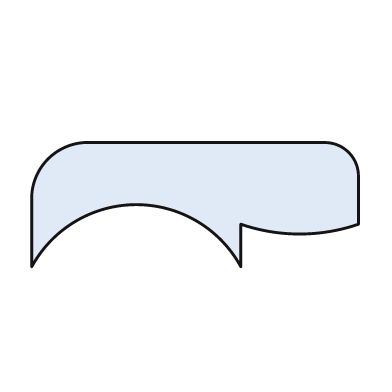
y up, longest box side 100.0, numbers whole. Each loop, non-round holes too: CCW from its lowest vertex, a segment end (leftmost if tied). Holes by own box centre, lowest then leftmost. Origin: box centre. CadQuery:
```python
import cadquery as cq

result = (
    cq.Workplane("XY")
    .moveTo(-50.0, -19.0)
    .threePointArc((-18.0, 0.0), (14.0, -19.0))
    .lineTo(14.0, -6.0)
    .threePointArc((32.0, -9.0), (50.0, -6.0))
    .lineTo(50.0, 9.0)
    .threePointArc((47.0, 16.0), (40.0, 19.0))
    .lineTo(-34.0, 19.0)
    .threePointArc((-45.0, 14.0), (-50.0, 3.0))
    .close()
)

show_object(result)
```